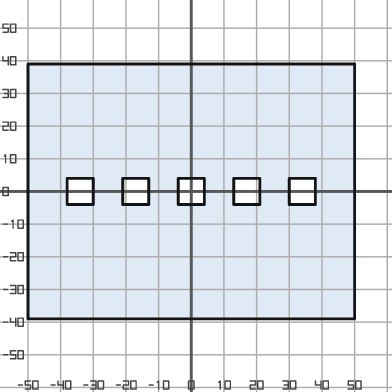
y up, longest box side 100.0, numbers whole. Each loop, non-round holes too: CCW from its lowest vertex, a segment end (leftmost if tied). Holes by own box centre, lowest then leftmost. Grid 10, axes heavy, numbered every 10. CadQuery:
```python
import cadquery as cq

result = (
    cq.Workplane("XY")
    .moveTo(-50.0, -39.0)
    .lineTo(50.0, -39.0)
    .lineTo(50.0, 39.0)
    .lineTo(-50.0, 39.0)
    .close()
    .moveTo(-38.0, -4.0)
    .lineTo(-30.0, -4.0)
    .lineTo(-30.0, 4.0)
    .lineTo(-38.0, 4.0)
    .close()
    .moveTo(-21.0, -4.0)
    .lineTo(-13.0, -4.0)
    .lineTo(-13.0, 4.0)
    .lineTo(-21.0, 4.0)
    .close()
    .moveTo(-4.0, -4.0)
    .lineTo(4.0, -4.0)
    .lineTo(4.0, 4.0)
    .lineTo(-4.0, 4.0)
    .close()
    .moveTo(13.0, -4.0)
    .lineTo(21.0, -4.0)
    .lineTo(21.0, 4.0)
    .lineTo(13.0, 4.0)
    .close()
    .moveTo(30.0, -4.0)
    .lineTo(38.0, -4.0)
    .lineTo(38.0, 4.0)
    .lineTo(30.0, 4.0)
    .close()
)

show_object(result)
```